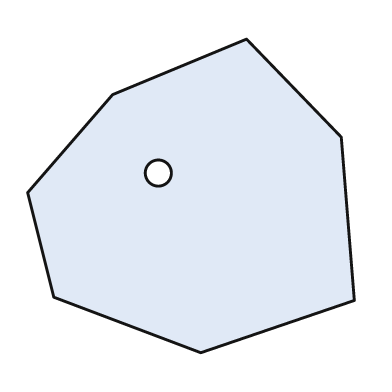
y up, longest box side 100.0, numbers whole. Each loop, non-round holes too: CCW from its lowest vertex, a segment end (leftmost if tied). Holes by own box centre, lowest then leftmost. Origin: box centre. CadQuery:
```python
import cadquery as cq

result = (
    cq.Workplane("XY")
    .moveTo(3.0, -48.0)
    .lineTo(50.0, -32.0)
    .lineTo(46.0, 18.0)
    .lineTo(17.0, 48.0)
    .lineTo(-24.0, 31.0)
    .lineTo(-50.0, 1.0)
    .lineTo(-42.0, -31.0)
    .close()
    .moveTo(-10.0, 7.0)
    .circle(4.0)
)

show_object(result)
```